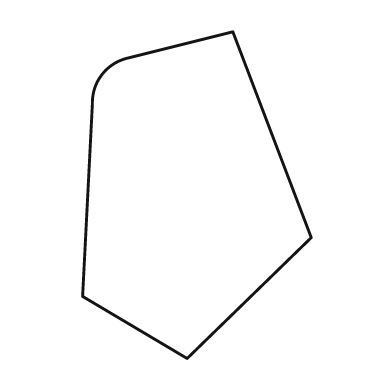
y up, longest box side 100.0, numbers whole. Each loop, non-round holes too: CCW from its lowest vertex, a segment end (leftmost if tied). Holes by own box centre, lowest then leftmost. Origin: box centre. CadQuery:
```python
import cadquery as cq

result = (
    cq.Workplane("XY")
    .moveTo(-3.0, -50.0)
    .lineTo(35.0, -13.0)
    .lineTo(11.0, 50.0)
    .lineTo(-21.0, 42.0)
    .threePointArc((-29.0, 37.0), (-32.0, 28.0))
    .lineTo(-35.0, -31.0)
    .close()
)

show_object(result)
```